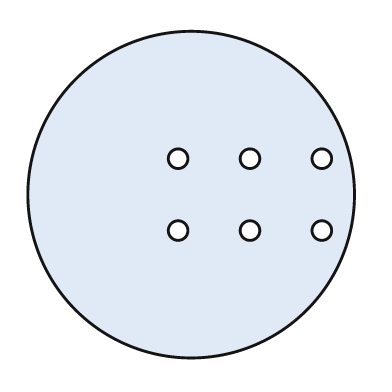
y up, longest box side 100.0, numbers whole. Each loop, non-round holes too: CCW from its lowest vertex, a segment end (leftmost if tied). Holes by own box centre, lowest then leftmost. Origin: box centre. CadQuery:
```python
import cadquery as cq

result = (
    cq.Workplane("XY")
    .moveTo(0.0, 0.0)
    .circle(50.0)
    .moveTo(-4.0, -11.0)
    .circle(3.0)
    .moveTo(18.0, -11.0)
    .circle(3.0)
    .moveTo(40.0, -11.0)
    .circle(3.0)
    .moveTo(-4.0, 11.0)
    .circle(3.0)
    .moveTo(18.0, 11.0)
    .circle(3.0)
    .moveTo(40.0, 11.0)
    .circle(3.0)
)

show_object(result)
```